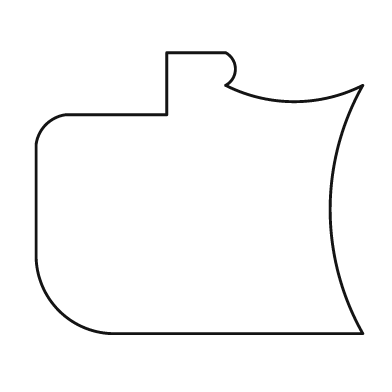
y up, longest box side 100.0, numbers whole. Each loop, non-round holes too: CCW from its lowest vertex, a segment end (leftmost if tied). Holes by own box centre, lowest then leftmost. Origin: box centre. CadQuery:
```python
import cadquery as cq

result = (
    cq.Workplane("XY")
    .moveTo(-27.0, -43.0)
    .lineTo(50.0, -43.0)
    .threePointArc((40.0, -5.0), (50.0, 33.0))
    .threePointArc((29.0, 28.0), (8.0, 33.0))
    .threePointArc((11.0, 38.0), (8.0, 43.0))
    .lineTo(-10.0, 43.0)
    .lineTo(-10.0, 24.0)
    .lineTo(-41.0, 24.0)
    .threePointArc((-47.0, 21.0), (-50.0, 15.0))
    .lineTo(-50.0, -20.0)
    .threePointArc((-43.0, -36.0), (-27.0, -43.0))
    .close()
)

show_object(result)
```